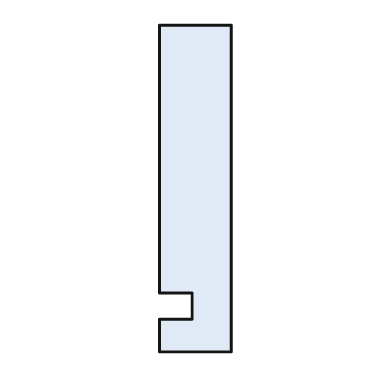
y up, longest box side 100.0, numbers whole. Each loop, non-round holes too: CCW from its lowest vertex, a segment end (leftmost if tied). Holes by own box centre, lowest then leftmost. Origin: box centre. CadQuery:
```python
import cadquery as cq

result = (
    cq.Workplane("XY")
    .moveTo(-11.0, -50.0)
    .lineTo(11.0, -50.0)
    .lineTo(11.0, 50.0)
    .lineTo(-11.0, 50.0)
    .lineTo(-11.0, -32.0)
    .lineTo(-1.0, -32.0)
    .lineTo(-1.0, -40.0)
    .lineTo(-11.0, -40.0)
    .close()
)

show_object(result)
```